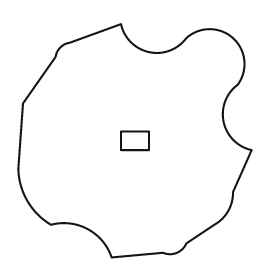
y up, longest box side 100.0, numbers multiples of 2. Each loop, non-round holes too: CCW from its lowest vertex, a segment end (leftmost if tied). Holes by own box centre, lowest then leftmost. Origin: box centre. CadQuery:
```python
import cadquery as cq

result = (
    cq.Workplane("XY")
    .moveTo(-10.0, -50.0)
    .lineTo(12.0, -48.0)
    .threePointArc((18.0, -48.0), (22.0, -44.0))
    .lineTo(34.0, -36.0)
    .threePointArc((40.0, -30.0), (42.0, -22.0))
    .lineTo(50.0, -4.0)
    .threePointArc((38.0, 8.0), (44.0, 24.0))
    .threePointArc((42.0, 44.0), (22.0, 44.0))
    .threePointArc((6.0, 38.0), (-6.0, 50.0))
    .lineTo(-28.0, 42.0)
    .threePointArc((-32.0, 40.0), (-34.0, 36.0))
    .lineTo(-48.0, 16.0)
    .lineTo(-50.0, -12.0)
    .threePointArc((-46.0, -26.0), (-36.0, -36.0))
    .threePointArc((-20.0, -38.0), (-10.0, -50.0))
    .close()
    .moveTo(-6.0, -4.0)
    .lineTo(6.0, -4.0)
    .lineTo(6.0, 4.0)
    .lineTo(-6.0, 4.0)
    .close()
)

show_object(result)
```